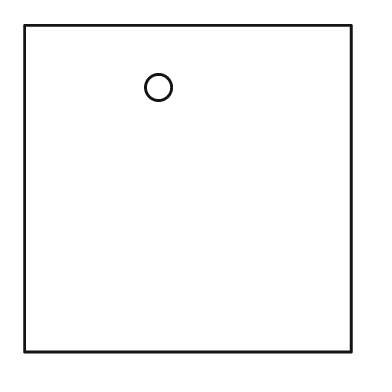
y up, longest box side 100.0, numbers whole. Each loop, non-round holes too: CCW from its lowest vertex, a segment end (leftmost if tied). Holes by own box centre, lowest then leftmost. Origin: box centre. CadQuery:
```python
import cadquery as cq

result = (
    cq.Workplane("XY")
    .moveTo(-50.0, -50.0)
    .lineTo(50.0, -50.0)
    .lineTo(50.0, 50.0)
    .lineTo(-50.0, 50.0)
    .close()
    .moveTo(-9.0, 31.0)
    .circle(4.0)
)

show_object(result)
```